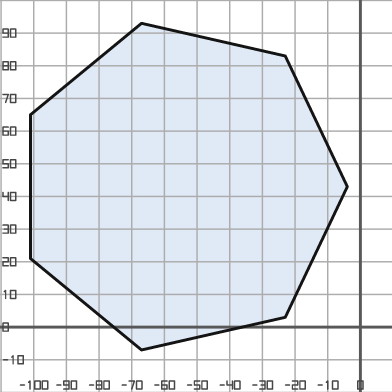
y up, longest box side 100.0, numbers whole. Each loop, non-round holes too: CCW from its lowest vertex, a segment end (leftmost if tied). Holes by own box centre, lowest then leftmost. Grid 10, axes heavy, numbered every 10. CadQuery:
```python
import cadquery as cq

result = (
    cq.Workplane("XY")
    .moveTo(-67.0, -7.0)
    .lineTo(-23.0, 3.0)
    .lineTo(-4.0, 43.0)
    .lineTo(-23.0, 83.0)
    .lineTo(-67.0, 93.0)
    .lineTo(-101.0, 65.0)
    .lineTo(-101.0, 21.0)
    .close()
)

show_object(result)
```